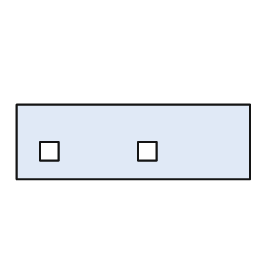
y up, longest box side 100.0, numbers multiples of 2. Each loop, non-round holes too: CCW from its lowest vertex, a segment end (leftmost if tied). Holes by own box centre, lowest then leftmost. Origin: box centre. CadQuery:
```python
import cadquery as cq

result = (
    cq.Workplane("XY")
    .moveTo(-50.0, -16.0)
    .lineTo(50.0, -16.0)
    .lineTo(50.0, 16.0)
    .lineTo(-50.0, 16.0)
    .close()
    .moveTo(-40.0, -8.0)
    .lineTo(-32.0, -8.0)
    .lineTo(-32.0, 0.0)
    .lineTo(-40.0, 0.0)
    .close()
    .moveTo(2.0, -8.0)
    .lineTo(10.0, -8.0)
    .lineTo(10.0, 0.0)
    .lineTo(2.0, 0.0)
    .close()
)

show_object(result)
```